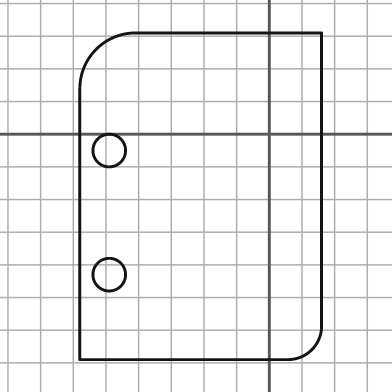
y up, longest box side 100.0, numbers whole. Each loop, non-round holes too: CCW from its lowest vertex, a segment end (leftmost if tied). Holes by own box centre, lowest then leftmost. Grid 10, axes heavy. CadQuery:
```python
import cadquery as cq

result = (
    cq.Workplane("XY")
    .moveTo(-58.0, -69.0)
    .lineTo(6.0, -69.0)
    .threePointArc((13.0, -66.0), (16.0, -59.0))
    .lineTo(16.0, 31.0)
    .lineTo(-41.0, 31.0)
    .threePointArc((-53.0, 26.0), (-58.0, 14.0))
    .close()
    .moveTo(-49.0, -43.0)
    .circle(5.0)
    .moveTo(-49.0, -5.0)
    .circle(5.0)
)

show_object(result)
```